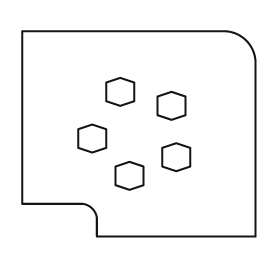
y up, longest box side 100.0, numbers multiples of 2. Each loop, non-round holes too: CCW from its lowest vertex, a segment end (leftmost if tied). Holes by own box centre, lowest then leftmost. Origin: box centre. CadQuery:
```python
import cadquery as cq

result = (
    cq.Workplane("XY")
    .moveTo(-18.0, -44.0)
    .lineTo(50.0, -44.0)
    .lineTo(50.0, 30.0)
    .threePointArc((46.0, 40.0), (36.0, 44.0))
    .lineTo(-50.0, 44.0)
    .lineTo(-50.0, -30.0)
    .lineTo(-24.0, -30.0)
    .threePointArc((-20.0, -32.0), (-18.0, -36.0))
    .close()
    .moveTo(-4.0, -24.0)
    .lineTo(2.0, -22.0)
    .lineTo(2.0, -14.0)
    .lineTo(-4.0, -12.0)
    .lineTo(-10.0, -14.0)
    .lineTo(-10.0, -22.0)
    .close()
    .moveTo(16.0, -16.0)
    .lineTo(22.0, -14.0)
    .lineTo(22.0, -6.0)
    .lineTo(16.0, -4.0)
    .lineTo(10.0, -6.0)
    .lineTo(10.0, -14.0)
    .close()
    .moveTo(-20.0, -8.0)
    .lineTo(-14.0, -6.0)
    .lineTo(-14.0, 2.0)
    .lineTo(-20.0, 4.0)
    .lineTo(-26.0, 2.0)
    .lineTo(-26.0, -6.0)
    .close()
    .moveTo(14.0, 6.0)
    .lineTo(20.0, 8.0)
    .lineTo(20.0, 16.0)
    .lineTo(14.0, 18.0)
    .lineTo(8.0, 16.0)
    .lineTo(8.0, 8.0)
    .close()
    .moveTo(-8.0, 12.0)
    .lineTo(-2.0, 14.0)
    .lineTo(-2.0, 22.0)
    .lineTo(-8.0, 24.0)
    .lineTo(-14.0, 22.0)
    .lineTo(-14.0, 14.0)
    .close()
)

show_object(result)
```